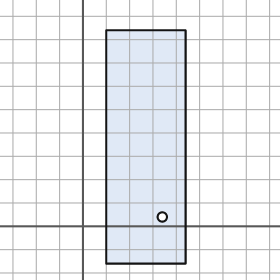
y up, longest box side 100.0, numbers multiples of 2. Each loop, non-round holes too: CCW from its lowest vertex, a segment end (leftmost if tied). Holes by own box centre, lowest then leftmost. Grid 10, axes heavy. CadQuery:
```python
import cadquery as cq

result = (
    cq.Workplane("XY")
    .moveTo(10.0, -16.0)
    .lineTo(44.0, -16.0)
    .lineTo(44.0, 84.0)
    .lineTo(10.0, 84.0)
    .close()
    .moveTo(34.0, 4.0)
    .circle(2.0)
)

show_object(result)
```